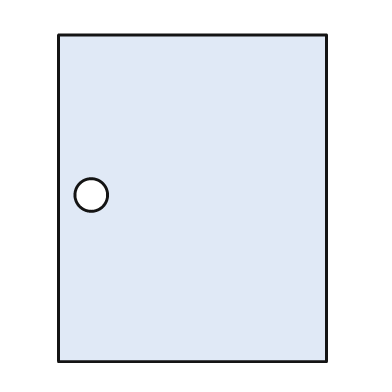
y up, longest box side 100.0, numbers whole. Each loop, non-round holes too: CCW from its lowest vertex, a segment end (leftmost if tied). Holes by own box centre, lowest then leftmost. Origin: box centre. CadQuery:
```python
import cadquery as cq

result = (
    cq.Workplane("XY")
    .moveTo(-41.0, -50.0)
    .lineTo(41.0, -50.0)
    .lineTo(41.0, 50.0)
    .lineTo(-41.0, 50.0)
    .close()
    .moveTo(-31.0, 1.0)
    .circle(5.0)
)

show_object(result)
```